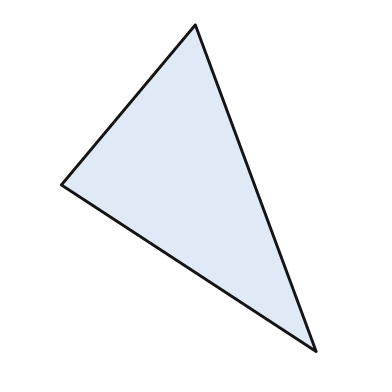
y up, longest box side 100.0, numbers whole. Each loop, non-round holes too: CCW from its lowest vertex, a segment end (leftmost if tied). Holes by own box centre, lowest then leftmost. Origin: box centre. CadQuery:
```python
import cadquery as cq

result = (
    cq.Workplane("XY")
    .moveTo(39.0, -50.0)
    .lineTo(2.0, 50.0)
    .lineTo(-39.0, 1.0)
    .close()
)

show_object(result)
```